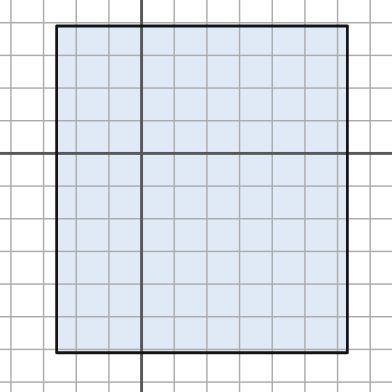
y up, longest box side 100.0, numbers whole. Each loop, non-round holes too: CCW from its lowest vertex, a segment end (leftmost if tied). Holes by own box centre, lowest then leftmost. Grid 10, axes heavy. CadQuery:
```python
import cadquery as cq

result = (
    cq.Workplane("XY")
    .moveTo(-26.0, -61.0)
    .lineTo(63.0, -61.0)
    .lineTo(63.0, 39.0)
    .lineTo(-26.0, 39.0)
    .close()
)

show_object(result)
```